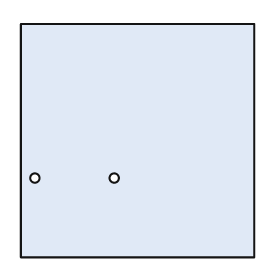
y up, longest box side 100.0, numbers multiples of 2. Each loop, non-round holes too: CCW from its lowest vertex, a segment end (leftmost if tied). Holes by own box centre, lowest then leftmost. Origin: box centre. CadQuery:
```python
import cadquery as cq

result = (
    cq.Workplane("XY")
    .moveTo(-50.0, -50.0)
    .lineTo(50.0, -50.0)
    .lineTo(50.0, 50.0)
    .lineTo(-50.0, 50.0)
    .close()
    .moveTo(-44.0, -16.0)
    .circle(2.0)
    .moveTo(-10.0, -16.0)
    .circle(2.0)
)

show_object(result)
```